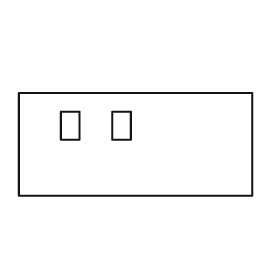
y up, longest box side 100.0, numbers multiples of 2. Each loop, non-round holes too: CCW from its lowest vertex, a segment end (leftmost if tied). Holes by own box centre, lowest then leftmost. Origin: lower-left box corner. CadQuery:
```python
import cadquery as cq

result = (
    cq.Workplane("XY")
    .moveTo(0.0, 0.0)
    .lineTo(100.0, 0.0)
    .lineTo(100.0, 44.0)
    .lineTo(0.0, 44.0)
    .close()
    .moveTo(18.0, 24.0)
    .lineTo(26.0, 24.0)
    .lineTo(26.0, 36.0)
    .lineTo(18.0, 36.0)
    .close()
    .moveTo(40.0, 24.0)
    .lineTo(48.0, 24.0)
    .lineTo(48.0, 36.0)
    .lineTo(40.0, 36.0)
    .close()
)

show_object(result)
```